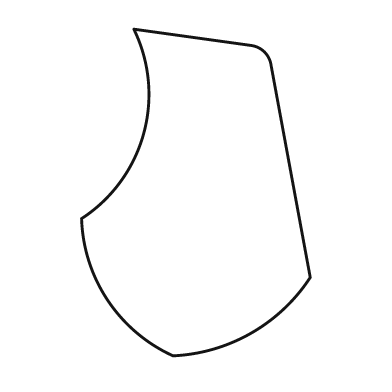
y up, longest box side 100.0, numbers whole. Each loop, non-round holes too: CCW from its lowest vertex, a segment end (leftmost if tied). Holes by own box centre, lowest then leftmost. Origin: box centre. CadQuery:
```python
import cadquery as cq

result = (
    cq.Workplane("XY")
    .moveTo(-7.0, -50.0)
    .threePointArc((17.0, -43.0), (35.0, -26.0))
    .lineTo(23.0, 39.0)
    .threePointArc((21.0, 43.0), (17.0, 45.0))
    .lineTo(-19.0, 50.0)
    .threePointArc((-16.0, 18.0), (-35.0, -8.0))
    .threePointArc((-27.0, -33.0), (-7.0, -50.0))
    .close()
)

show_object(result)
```